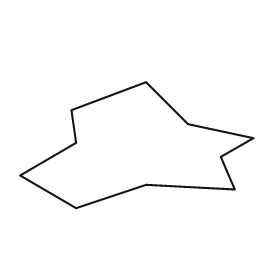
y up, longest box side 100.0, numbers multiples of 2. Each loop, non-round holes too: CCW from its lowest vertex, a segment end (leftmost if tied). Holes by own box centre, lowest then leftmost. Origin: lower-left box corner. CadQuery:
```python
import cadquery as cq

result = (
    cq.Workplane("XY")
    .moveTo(24.0, 0.0)
    .lineTo(54.0, 10.0)
    .lineTo(92.0, 8.0)
    .lineTo(86.0, 22.0)
    .lineTo(100.0, 30.0)
    .lineTo(72.0, 36.0)
    .lineTo(54.0, 54.0)
    .lineTo(22.0, 42.0)
    .lineTo(24.0, 28.0)
    .lineTo(0.0, 14.0)
    .close()
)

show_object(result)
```